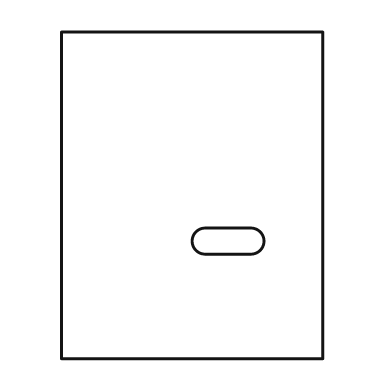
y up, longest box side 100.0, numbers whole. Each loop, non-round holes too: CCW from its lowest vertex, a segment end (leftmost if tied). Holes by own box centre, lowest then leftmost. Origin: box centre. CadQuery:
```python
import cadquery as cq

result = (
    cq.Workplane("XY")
    .moveTo(-40.0, -50.0)
    .lineTo(40.0, -50.0)
    .lineTo(40.0, 50.0)
    .lineTo(-40.0, 50.0)
    .close()
    .moveTo(4.0, -18.0)
    .lineTo(18.0, -18.0)
    .threePointArc((22.0, -14.0), (18.0, -10.0))
    .lineTo(4.0, -10.0)
    .threePointArc((0.0, -14.0), (4.0, -18.0))
    .close()
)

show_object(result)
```